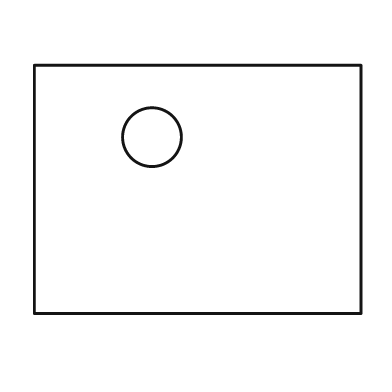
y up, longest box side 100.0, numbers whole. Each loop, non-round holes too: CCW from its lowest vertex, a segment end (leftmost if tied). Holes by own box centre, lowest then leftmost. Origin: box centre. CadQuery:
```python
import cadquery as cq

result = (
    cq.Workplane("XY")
    .moveTo(-50.0, -38.0)
    .lineTo(50.0, -38.0)
    .lineTo(50.0, 38.0)
    .lineTo(-50.0, 38.0)
    .close()
    .moveTo(-14.0, 16.0)
    .circle(9.0)
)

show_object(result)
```